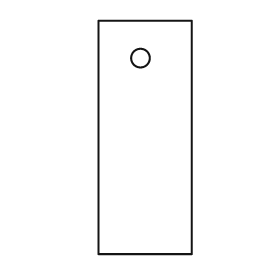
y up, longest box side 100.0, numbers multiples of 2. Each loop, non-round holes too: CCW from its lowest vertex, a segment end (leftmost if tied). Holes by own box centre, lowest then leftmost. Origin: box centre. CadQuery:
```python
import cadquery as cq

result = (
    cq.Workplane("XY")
    .moveTo(-20.0, -50.0)
    .lineTo(20.0, -50.0)
    .lineTo(20.0, 50.0)
    .lineTo(-20.0, 50.0)
    .close()
    .moveTo(-2.0, 34.0)
    .circle(4.0)
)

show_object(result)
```